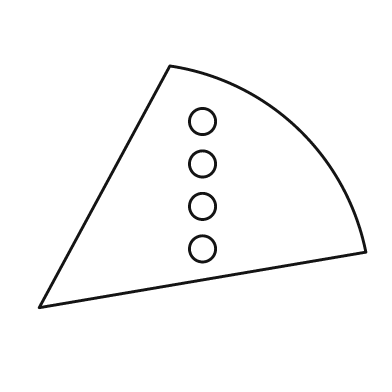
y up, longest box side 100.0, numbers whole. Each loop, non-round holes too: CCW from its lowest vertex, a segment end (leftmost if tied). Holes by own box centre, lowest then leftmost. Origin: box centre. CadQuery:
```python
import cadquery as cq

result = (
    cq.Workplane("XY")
    .moveTo(-50.0, -37.0)
    .lineTo(50.0, -20.0)
    .threePointArc((29.0, 18.0), (-10.0, 37.0))
    .close()
    .moveTo(0.0, -19.0)
    .circle(4.0)
    .moveTo(0.0, -6.0)
    .circle(4.0)
    .moveTo(0.0, 7.0)
    .circle(4.0)
    .moveTo(0.0, 20.0)
    .circle(4.0)
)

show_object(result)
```